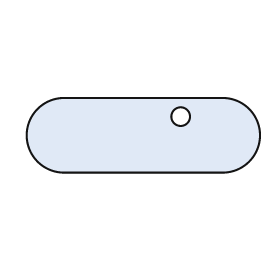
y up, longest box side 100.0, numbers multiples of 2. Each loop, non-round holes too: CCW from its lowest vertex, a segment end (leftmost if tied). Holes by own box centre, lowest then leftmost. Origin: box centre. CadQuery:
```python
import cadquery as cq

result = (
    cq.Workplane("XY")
    .moveTo(-34.0, -16.0)
    .lineTo(34.0, -16.0)
    .threePointArc((50.0, 0.0), (34.0, 16.0))
    .lineTo(-34.0, 16.0)
    .threePointArc((-50.0, 0.0), (-34.0, -16.0))
    .close()
    .moveTo(16.0, 8.0)
    .circle(4.0)
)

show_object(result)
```